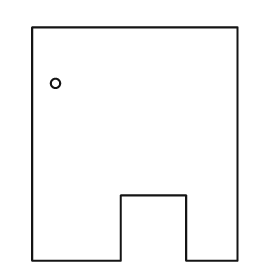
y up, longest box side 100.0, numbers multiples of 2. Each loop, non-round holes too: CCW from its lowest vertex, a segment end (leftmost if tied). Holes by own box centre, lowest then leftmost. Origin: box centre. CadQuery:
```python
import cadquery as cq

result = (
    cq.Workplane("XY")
    .moveTo(-44.0, -50.0)
    .lineTo(-6.0, -50.0)
    .lineTo(-6.0, -22.0)
    .lineTo(22.0, -22.0)
    .lineTo(22.0, -50.0)
    .lineTo(44.0, -50.0)
    .lineTo(44.0, 50.0)
    .lineTo(-44.0, 50.0)
    .close()
    .moveTo(-34.0, 26.0)
    .circle(2.0)
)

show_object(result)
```